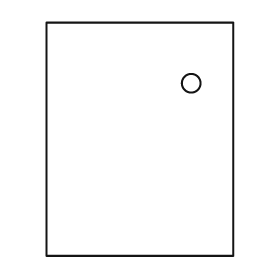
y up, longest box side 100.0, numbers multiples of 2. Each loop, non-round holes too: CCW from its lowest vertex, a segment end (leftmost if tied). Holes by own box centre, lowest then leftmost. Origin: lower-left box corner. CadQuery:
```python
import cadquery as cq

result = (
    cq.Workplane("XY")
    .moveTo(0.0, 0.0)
    .lineTo(80.0, 0.0)
    .lineTo(80.0, 100.0)
    .lineTo(0.0, 100.0)
    .close()
    .moveTo(62.0, 74.0)
    .circle(4.0)
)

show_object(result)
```